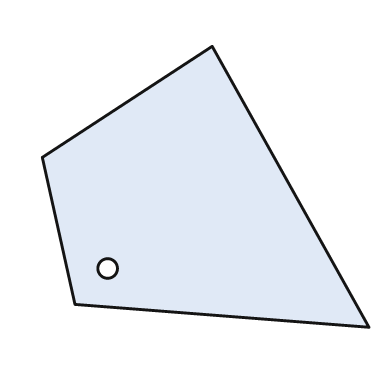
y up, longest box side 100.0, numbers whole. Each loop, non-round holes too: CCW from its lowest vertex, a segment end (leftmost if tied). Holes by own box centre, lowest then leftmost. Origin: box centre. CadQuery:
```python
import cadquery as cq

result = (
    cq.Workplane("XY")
    .moveTo(50.0, -43.0)
    .lineTo(2.0, 43.0)
    .lineTo(-50.0, 9.0)
    .lineTo(-40.0, -36.0)
    .close()
    .moveTo(-30.0, -25.0)
    .circle(3.0)
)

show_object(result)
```